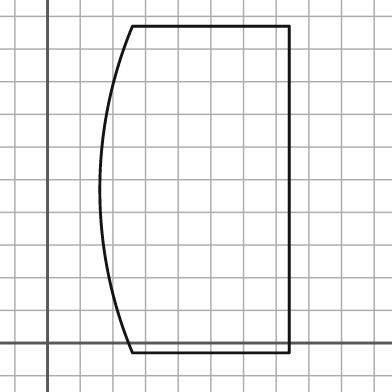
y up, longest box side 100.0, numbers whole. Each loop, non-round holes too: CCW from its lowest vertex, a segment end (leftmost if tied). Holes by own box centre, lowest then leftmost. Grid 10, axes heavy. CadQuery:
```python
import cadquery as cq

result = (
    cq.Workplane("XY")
    .moveTo(26.0, -3.0)
    .lineTo(74.0, -3.0)
    .lineTo(74.0, 97.0)
    .lineTo(26.0, 97.0)
    .threePointArc((16.0, 47.0), (26.0, -3.0))
    .close()
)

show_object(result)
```